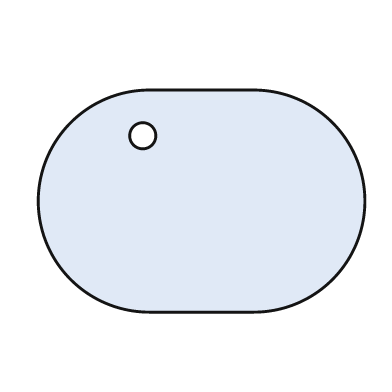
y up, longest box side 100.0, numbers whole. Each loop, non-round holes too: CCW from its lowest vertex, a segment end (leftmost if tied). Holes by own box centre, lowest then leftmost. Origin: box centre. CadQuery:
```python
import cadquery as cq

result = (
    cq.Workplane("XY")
    .moveTo(-16.0, -34.0)
    .lineTo(16.0, -34.0)
    .threePointArc((50.0, 0.0), (16.0, 34.0))
    .lineTo(-16.0, 34.0)
    .threePointArc((-50.0, 0.0), (-16.0, -34.0))
    .close()
    .moveTo(-18.0, 20.0)
    .circle(4.0)
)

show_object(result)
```